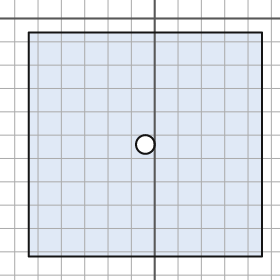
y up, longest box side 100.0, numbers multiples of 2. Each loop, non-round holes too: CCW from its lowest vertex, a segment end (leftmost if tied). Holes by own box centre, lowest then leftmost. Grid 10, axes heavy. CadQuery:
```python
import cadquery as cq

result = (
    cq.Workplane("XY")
    .moveTo(-54.0, -102.0)
    .lineTo(46.0, -102.0)
    .lineTo(46.0, -6.0)
    .lineTo(-54.0, -6.0)
    .close()
    .moveTo(-4.0, -54.0)
    .circle(4.0)
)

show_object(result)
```